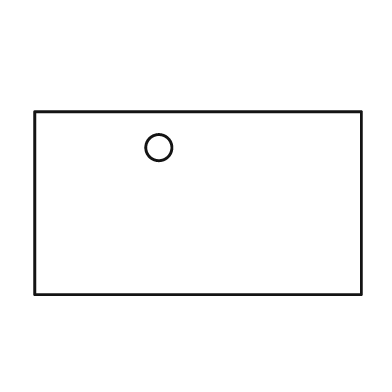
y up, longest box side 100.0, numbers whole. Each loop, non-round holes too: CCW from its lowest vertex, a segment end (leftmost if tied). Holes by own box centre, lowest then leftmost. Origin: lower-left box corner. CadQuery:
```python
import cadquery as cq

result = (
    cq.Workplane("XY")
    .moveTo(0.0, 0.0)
    .lineTo(100.0, 0.0)
    .lineTo(100.0, 56.0)
    .lineTo(0.0, 56.0)
    .close()
    .moveTo(38.0, 45.0)
    .circle(4.0)
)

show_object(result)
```